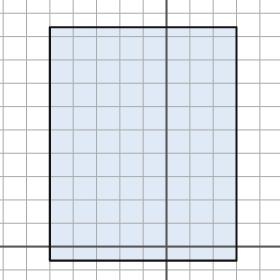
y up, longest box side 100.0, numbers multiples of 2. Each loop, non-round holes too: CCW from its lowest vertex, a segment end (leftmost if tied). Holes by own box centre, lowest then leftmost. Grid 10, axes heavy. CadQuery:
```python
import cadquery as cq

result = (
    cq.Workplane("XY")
    .moveTo(-50.0, -6.0)
    .lineTo(30.0, -6.0)
    .lineTo(30.0, 94.0)
    .lineTo(-50.0, 94.0)
    .close()
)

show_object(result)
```